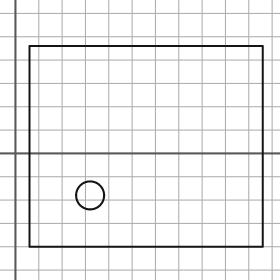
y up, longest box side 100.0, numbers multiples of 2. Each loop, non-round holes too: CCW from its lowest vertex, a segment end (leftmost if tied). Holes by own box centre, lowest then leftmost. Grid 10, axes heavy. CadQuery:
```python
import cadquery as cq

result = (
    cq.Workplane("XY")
    .moveTo(6.0, -40.0)
    .lineTo(106.0, -40.0)
    .lineTo(106.0, 46.0)
    .lineTo(6.0, 46.0)
    .close()
    .moveTo(32.0, -18.0)
    .circle(6.0)
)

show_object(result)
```